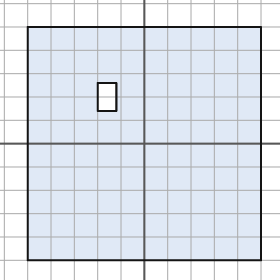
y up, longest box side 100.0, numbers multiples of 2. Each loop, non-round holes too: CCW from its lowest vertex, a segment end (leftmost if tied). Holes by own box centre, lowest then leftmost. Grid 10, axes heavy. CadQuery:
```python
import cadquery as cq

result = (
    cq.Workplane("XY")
    .moveTo(-50.0, -50.0)
    .lineTo(50.0, -50.0)
    .lineTo(50.0, 50.0)
    .lineTo(-50.0, 50.0)
    .close()
    .moveTo(-20.0, 14.0)
    .lineTo(-12.0, 14.0)
    .lineTo(-12.0, 26.0)
    .lineTo(-20.0, 26.0)
    .close()
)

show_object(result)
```